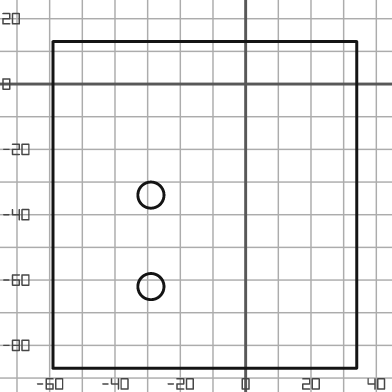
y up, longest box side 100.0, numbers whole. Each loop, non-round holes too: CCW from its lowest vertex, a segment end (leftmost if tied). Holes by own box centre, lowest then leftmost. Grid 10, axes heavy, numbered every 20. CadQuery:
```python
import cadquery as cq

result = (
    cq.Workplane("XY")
    .moveTo(-59.0, -87.0)
    .lineTo(34.0, -87.0)
    .lineTo(34.0, 13.0)
    .lineTo(-59.0, 13.0)
    .close()
    .moveTo(-29.0, -62.0)
    .circle(4.0)
    .moveTo(-29.0, -34.0)
    .circle(4.0)
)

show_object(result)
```